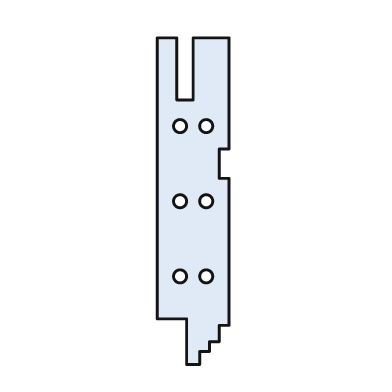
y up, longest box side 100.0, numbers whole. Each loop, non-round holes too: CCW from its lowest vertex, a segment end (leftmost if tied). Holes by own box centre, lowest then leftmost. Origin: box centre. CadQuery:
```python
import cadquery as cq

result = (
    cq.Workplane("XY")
    .moveTo(-2.0, -50.0)
    .lineTo(2.0, -50.0)
    .lineTo(2.0, -46.0)
    .lineTo(5.0, -46.0)
    .lineTo(5.0, -43.0)
    .lineTo(8.0, -43.0)
    .lineTo(8.0, -38.0)
    .lineTo(11.0, -38.0)
    .lineTo(11.0, 7.0)
    .lineTo(8.0, 7.0)
    .lineTo(8.0, 16.0)
    .lineTo(11.0, 16.0)
    .lineTo(11.0, 50.0)
    .lineTo(0.0, 50.0)
    .lineTo(0.0, 31.0)
    .lineTo(-5.0, 31.0)
    .lineTo(-5.0, 50.0)
    .lineTo(-11.0, 50.0)
    .lineTo(-11.0, -36.0)
    .lineTo(-2.0, -36.0)
    .close()
    .moveTo(-4.0, -23.0)
    .circle(2.0)
    .moveTo(4.0, -23.0)
    .circle(2.0)
    .moveTo(-4.0, 0.0)
    .circle(2.0)
    .moveTo(4.0, 0.0)
    .circle(2.0)
    .moveTo(-4.0, 23.0)
    .circle(2.0)
    .moveTo(4.0, 23.0)
    .circle(2.0)
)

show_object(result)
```